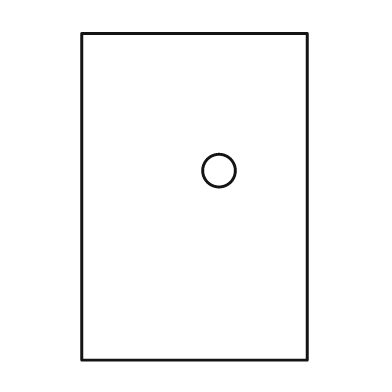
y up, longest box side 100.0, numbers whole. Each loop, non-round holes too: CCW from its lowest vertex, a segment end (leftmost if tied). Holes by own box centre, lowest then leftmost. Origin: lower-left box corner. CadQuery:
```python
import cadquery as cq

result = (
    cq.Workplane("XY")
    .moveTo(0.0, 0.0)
    .lineTo(69.0, 0.0)
    .lineTo(69.0, 100.0)
    .lineTo(0.0, 100.0)
    .close()
    .moveTo(42.0, 58.0)
    .circle(5.0)
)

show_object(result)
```